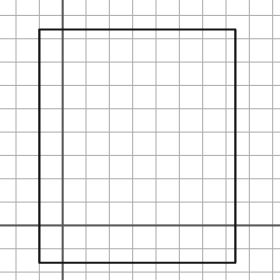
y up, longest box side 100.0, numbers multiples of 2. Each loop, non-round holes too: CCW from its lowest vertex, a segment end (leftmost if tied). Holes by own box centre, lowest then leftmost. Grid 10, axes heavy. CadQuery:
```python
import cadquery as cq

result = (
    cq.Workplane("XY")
    .moveTo(-10.0, -16.0)
    .lineTo(74.0, -16.0)
    .lineTo(74.0, 84.0)
    .lineTo(-10.0, 84.0)
    .close()
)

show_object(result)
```